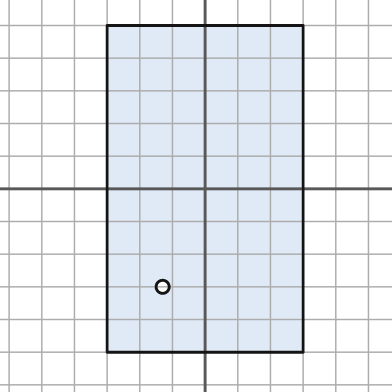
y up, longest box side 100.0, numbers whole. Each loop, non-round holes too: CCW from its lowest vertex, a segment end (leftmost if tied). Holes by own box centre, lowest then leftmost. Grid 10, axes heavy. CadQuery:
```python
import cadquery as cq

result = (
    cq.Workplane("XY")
    .moveTo(-30.0, -50.0)
    .lineTo(30.0, -50.0)
    .lineTo(30.0, 50.0)
    .lineTo(-30.0, 50.0)
    .close()
    .moveTo(-13.0, -30.0)
    .circle(2.0)
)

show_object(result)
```